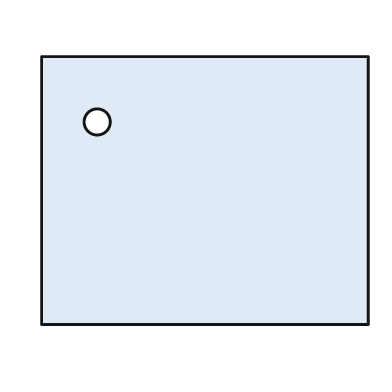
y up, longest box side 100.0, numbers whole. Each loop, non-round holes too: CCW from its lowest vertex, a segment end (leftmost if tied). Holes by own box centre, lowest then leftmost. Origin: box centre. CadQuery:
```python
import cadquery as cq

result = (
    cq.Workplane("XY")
    .moveTo(-50.0, -41.0)
    .lineTo(50.0, -41.0)
    .lineTo(50.0, 41.0)
    .lineTo(-50.0, 41.0)
    .close()
    .moveTo(-33.0, 21.0)
    .circle(4.0)
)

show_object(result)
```